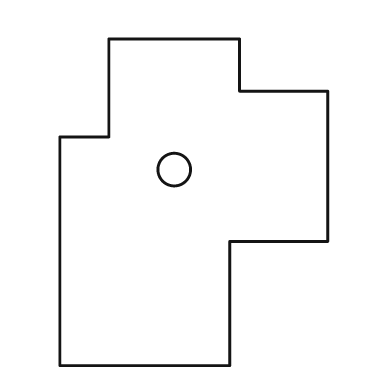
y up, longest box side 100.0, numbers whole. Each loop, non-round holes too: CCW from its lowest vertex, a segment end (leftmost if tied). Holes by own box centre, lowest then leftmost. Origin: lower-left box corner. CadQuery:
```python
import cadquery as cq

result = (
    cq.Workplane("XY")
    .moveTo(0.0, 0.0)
    .lineTo(52.0, 0.0)
    .lineTo(52.0, 38.0)
    .lineTo(82.0, 38.0)
    .lineTo(82.0, 84.0)
    .lineTo(55.0, 84.0)
    .lineTo(55.0, 100.0)
    .lineTo(15.0, 100.0)
    .lineTo(15.0, 70.0)
    .lineTo(0.0, 70.0)
    .close()
    .moveTo(35.0, 60.0)
    .circle(5.0)
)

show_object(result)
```